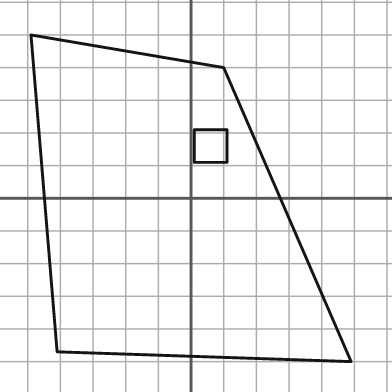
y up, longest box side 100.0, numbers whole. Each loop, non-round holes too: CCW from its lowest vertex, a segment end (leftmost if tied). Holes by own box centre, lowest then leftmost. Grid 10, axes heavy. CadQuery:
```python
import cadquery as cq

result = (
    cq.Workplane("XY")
    .moveTo(49.0, -50.0)
    .lineTo(10.0, 40.0)
    .lineTo(-49.0, 50.0)
    .lineTo(-41.0, -47.0)
    .close()
    .moveTo(1.0, 11.0)
    .lineTo(11.0, 11.0)
    .lineTo(11.0, 21.0)
    .lineTo(1.0, 21.0)
    .close()
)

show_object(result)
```